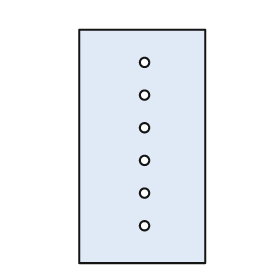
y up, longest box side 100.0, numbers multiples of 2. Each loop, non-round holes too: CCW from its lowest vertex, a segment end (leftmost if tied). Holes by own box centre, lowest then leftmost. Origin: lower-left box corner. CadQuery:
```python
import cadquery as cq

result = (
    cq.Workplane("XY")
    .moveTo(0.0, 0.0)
    .lineTo(54.0, 0.0)
    .lineTo(54.0, 100.0)
    .lineTo(0.0, 100.0)
    .close()
    .moveTo(28.0, 16.0)
    .circle(2.0)
    .moveTo(28.0, 30.0)
    .circle(2.0)
    .moveTo(28.0, 44.0)
    .circle(2.0)
    .moveTo(28.0, 58.0)
    .circle(2.0)
    .moveTo(28.0, 72.0)
    .circle(2.0)
    .moveTo(28.0, 86.0)
    .circle(2.0)
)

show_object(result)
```